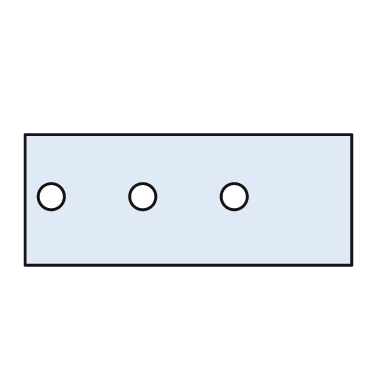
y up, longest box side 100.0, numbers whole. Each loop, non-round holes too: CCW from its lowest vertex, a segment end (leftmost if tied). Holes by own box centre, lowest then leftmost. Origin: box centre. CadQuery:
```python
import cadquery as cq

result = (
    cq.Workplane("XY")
    .moveTo(-50.0, -20.0)
    .lineTo(50.0, -20.0)
    .lineTo(50.0, 20.0)
    .lineTo(-50.0, 20.0)
    .close()
    .moveTo(-42.0, 1.0)
    .circle(4.0)
    .moveTo(-14.0, 1.0)
    .circle(4.0)
    .moveTo(14.0, 1.0)
    .circle(4.0)
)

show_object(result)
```